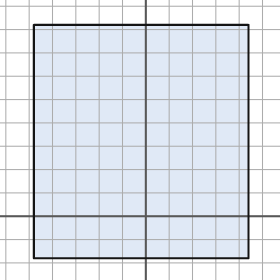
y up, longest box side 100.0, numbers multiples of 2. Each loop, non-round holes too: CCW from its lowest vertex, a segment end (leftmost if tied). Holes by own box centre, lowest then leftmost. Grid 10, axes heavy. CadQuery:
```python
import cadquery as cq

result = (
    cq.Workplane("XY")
    .moveTo(-48.0, -18.0)
    .lineTo(44.0, -18.0)
    .lineTo(44.0, 82.0)
    .lineTo(-48.0, 82.0)
    .close()
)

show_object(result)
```